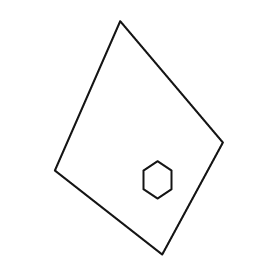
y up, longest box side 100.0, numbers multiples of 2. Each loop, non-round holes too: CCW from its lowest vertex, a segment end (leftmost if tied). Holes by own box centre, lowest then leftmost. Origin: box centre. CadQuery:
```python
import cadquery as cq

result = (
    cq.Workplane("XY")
    .moveTo(10.0, -50.0)
    .lineTo(36.0, -2.0)
    .lineTo(-8.0, 50.0)
    .lineTo(-36.0, -14.0)
    .close()
    .moveTo(8.0, -26.0)
    .lineTo(14.0, -22.0)
    .lineTo(14.0, -14.0)
    .lineTo(8.0, -10.0)
    .lineTo(2.0, -14.0)
    .lineTo(2.0, -22.0)
    .close()
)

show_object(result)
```